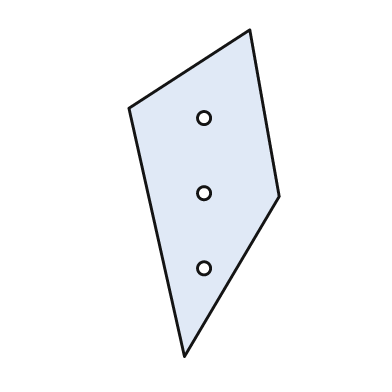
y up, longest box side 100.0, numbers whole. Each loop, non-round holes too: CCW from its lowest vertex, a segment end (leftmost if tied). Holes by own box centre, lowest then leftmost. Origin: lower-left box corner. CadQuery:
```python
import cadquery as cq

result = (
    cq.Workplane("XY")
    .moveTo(17.0, 0.0)
    .lineTo(46.0, 49.0)
    .lineTo(37.0, 100.0)
    .lineTo(0.0, 76.0)
    .close()
    .moveTo(23.0, 27.0)
    .circle(2.0)
    .moveTo(23.0, 50.0)
    .circle(2.0)
    .moveTo(23.0, 73.0)
    .circle(2.0)
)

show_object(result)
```